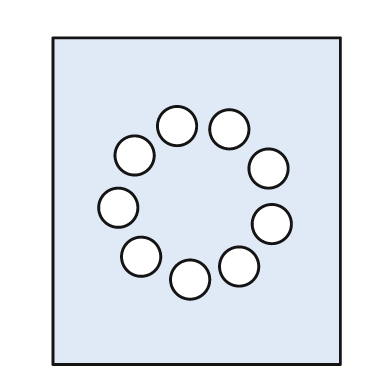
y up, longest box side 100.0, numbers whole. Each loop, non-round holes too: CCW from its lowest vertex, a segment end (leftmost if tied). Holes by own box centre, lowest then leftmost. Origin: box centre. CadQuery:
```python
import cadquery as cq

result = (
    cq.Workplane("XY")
    .moveTo(-44.0, -50.0)
    .lineTo(44.0, -50.0)
    .lineTo(44.0, 50.0)
    .lineTo(-44.0, 50.0)
    .close()
    .moveTo(-2.0, -24.0)
    .circle(6.0)
    .moveTo(13.0, -20.0)
    .circle(6.0)
    .moveTo(-17.0, -17.0)
    .circle(6.0)
    .moveTo(23.0, -7.0)
    .circle(6.0)
    .moveTo(-24.0, -2.0)
    .circle(6.0)
    .moveTo(22.0, 10.0)
    .circle(6.0)
    .moveTo(-19.0, 14.0)
    .circle(6.0)
    .moveTo(10.0, 22.0)
    .circle(6.0)
    .moveTo(-6.0, 23.0)
    .circle(6.0)
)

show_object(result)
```